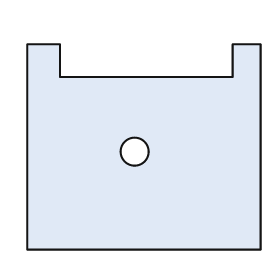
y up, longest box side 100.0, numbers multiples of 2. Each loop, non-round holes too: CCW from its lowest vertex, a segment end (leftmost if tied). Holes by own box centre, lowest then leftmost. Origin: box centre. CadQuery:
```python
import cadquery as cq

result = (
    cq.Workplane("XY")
    .moveTo(-50.0, -44.0)
    .lineTo(50.0, -44.0)
    .lineTo(50.0, 44.0)
    .lineTo(38.0, 44.0)
    .lineTo(38.0, 30.0)
    .lineTo(-36.0, 30.0)
    .lineTo(-36.0, 44.0)
    .lineTo(-50.0, 44.0)
    .close()
    .moveTo(-4.0, -2.0)
    .circle(6.0)
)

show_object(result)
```